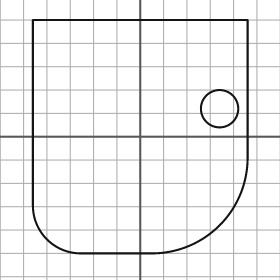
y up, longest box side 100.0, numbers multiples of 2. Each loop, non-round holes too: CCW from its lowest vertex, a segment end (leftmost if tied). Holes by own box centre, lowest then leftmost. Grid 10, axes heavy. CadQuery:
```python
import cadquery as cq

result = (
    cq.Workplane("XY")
    .moveTo(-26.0, -50.0)
    .lineTo(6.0, -50.0)
    .threePointArc((34.0, -38.0), (46.0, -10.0))
    .lineTo(46.0, 50.0)
    .lineTo(-46.0, 50.0)
    .lineTo(-46.0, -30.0)
    .threePointArc((-40.0, -44.0), (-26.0, -50.0))
    .close()
    .moveTo(34.0, 12.0)
    .circle(8.0)
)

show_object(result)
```